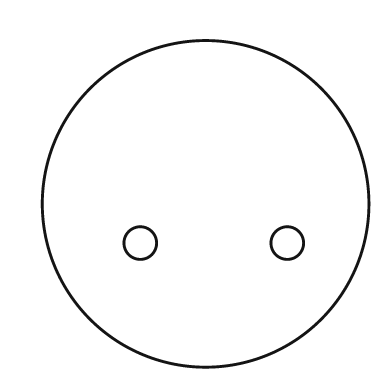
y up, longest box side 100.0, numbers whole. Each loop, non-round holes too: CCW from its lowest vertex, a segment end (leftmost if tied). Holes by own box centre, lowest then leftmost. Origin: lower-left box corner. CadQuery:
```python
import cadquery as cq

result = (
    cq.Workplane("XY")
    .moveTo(50.0, 50.0)
    .circle(50.0)
    .moveTo(30.0, 38.0)
    .circle(5.0)
    .moveTo(75.0, 38.0)
    .circle(5.0)
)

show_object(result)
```